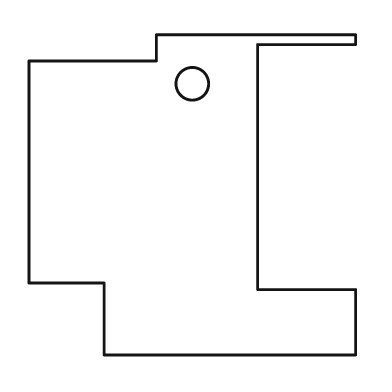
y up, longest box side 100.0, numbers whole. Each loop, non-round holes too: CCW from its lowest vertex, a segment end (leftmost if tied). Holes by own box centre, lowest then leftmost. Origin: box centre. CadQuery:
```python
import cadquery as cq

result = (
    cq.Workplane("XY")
    .moveTo(-27.0, -49.0)
    .lineTo(50.0, -49.0)
    .lineTo(50.0, -29.0)
    .lineTo(20.0, -29.0)
    .lineTo(20.0, 46.0)
    .lineTo(50.0, 46.0)
    .lineTo(50.0, 49.0)
    .lineTo(-11.0, 49.0)
    .lineTo(-11.0, 41.0)
    .lineTo(-50.0, 41.0)
    .lineTo(-50.0, -27.0)
    .lineTo(-27.0, -27.0)
    .close()
    .moveTo(0.0, 34.0)
    .circle(5.0)
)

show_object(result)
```